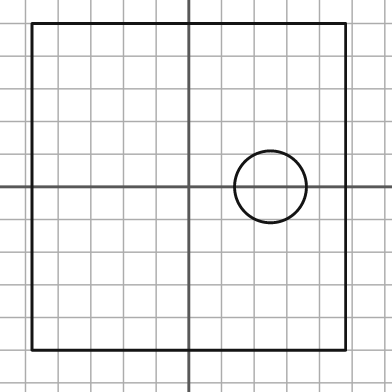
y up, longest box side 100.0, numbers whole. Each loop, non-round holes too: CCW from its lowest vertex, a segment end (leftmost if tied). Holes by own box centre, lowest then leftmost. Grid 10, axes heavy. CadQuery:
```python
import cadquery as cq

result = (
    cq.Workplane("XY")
    .moveTo(-48.0, -50.0)
    .lineTo(48.0, -50.0)
    .lineTo(48.0, 50.0)
    .lineTo(-48.0, 50.0)
    .close()
    .moveTo(25.0, 0.0)
    .circle(11.0)
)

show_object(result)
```